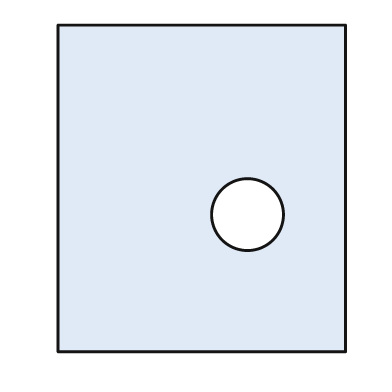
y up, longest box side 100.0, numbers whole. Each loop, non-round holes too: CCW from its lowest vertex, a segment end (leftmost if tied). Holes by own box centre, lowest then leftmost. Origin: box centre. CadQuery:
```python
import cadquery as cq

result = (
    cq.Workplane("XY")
    .moveTo(-44.0, -50.0)
    .lineTo(44.0, -50.0)
    .lineTo(44.0, 50.0)
    .lineTo(-44.0, 50.0)
    .close()
    .moveTo(14.0, -8.0)
    .circle(11.0)
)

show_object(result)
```